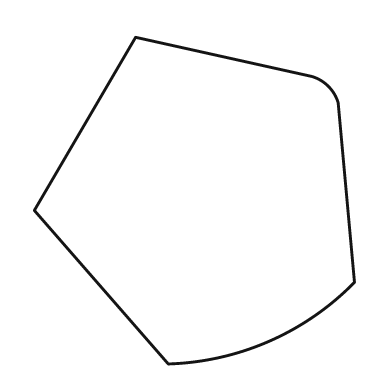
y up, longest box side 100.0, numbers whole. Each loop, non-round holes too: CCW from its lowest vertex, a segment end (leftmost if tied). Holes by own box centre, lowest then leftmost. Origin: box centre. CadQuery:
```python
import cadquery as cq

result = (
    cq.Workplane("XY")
    .moveTo(-8.0, -50.0)
    .threePointArc((23.0, -43.0), (49.0, -25.0))
    .lineTo(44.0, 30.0)
    .threePointArc((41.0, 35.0), (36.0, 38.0))
    .lineTo(-18.0, 50.0)
    .lineTo(-49.0, -3.0)
    .close()
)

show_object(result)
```